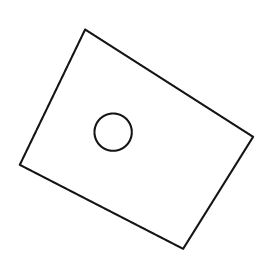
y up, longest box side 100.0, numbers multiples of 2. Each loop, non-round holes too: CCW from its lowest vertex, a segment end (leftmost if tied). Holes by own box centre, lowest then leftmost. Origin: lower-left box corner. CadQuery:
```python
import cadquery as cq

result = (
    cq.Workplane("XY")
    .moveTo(70.0, 0.0)
    .lineTo(100.0, 48.0)
    .lineTo(28.0, 94.0)
    .lineTo(0.0, 36.0)
    .close()
    .moveTo(40.0, 50.0)
    .circle(8.0)
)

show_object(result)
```